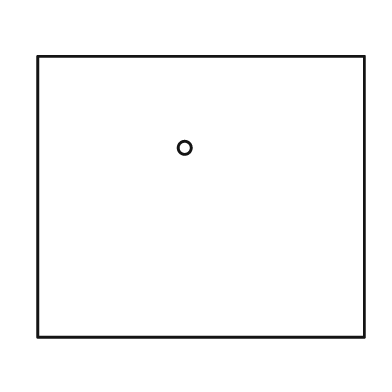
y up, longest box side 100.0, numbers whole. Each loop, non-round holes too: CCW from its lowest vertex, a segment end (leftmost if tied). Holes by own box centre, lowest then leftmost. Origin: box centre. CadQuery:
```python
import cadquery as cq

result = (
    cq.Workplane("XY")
    .moveTo(-50.0, -43.0)
    .lineTo(50.0, -43.0)
    .lineTo(50.0, 43.0)
    .lineTo(-50.0, 43.0)
    .close()
    .moveTo(-5.0, 15.0)
    .circle(2.0)
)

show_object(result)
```